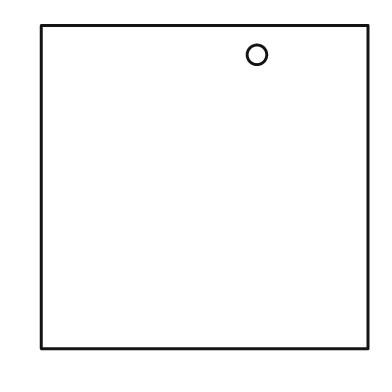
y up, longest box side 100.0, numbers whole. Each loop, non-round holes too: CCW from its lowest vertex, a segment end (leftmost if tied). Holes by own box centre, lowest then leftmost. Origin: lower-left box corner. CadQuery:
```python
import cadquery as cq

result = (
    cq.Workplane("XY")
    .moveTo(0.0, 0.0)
    .lineTo(100.0, 0.0)
    .lineTo(100.0, 99.0)
    .lineTo(0.0, 99.0)
    .close()
    .moveTo(66.0, 90.0)
    .circle(3.0)
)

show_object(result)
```